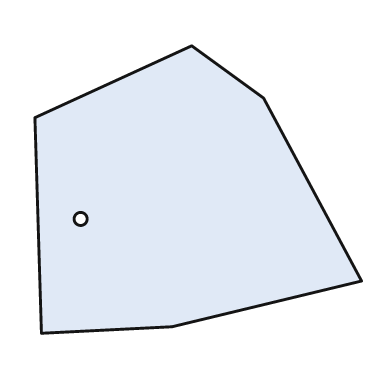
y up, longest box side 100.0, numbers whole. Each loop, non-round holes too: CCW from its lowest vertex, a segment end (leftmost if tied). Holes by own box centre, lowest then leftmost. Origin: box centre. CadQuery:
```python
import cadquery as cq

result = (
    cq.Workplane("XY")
    .moveTo(-48.0, -44.0)
    .lineTo(-8.0, -42.0)
    .lineTo(50.0, -28.0)
    .lineTo(20.0, 28.0)
    .lineTo(-2.0, 44.0)
    .lineTo(-50.0, 22.0)
    .close()
    .moveTo(-36.0, -9.0)
    .circle(2.0)
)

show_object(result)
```